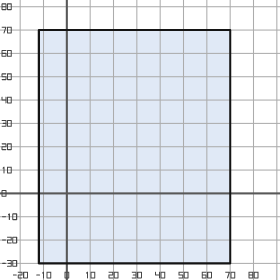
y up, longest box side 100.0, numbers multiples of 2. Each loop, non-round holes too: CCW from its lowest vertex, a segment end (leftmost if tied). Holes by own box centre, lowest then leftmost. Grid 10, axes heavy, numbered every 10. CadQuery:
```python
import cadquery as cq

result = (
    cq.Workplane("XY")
    .moveTo(-12.0, -30.0)
    .lineTo(70.0, -30.0)
    .lineTo(70.0, 70.0)
    .lineTo(-12.0, 70.0)
    .close()
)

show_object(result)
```